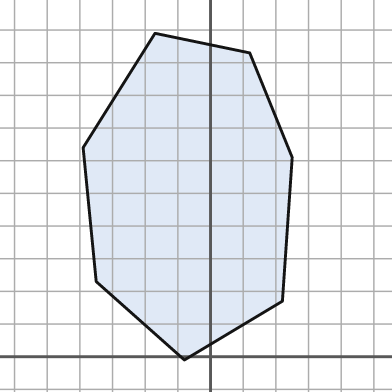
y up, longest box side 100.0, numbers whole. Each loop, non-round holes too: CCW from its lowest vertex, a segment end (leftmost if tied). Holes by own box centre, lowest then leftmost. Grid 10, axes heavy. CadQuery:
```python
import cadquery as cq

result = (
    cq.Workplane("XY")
    .moveTo(-8.0, -1.0)
    .lineTo(22.0, 17.0)
    .lineTo(25.0, 61.0)
    .lineTo(12.0, 93.0)
    .lineTo(-17.0, 99.0)
    .lineTo(-39.0, 64.0)
    .lineTo(-35.0, 23.0)
    .close()
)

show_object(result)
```